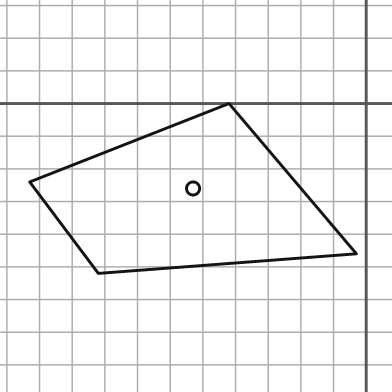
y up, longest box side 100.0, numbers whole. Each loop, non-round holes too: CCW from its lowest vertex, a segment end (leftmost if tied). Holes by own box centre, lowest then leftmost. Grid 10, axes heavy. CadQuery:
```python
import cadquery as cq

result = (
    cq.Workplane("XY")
    .moveTo(-82.0, -52.0)
    .lineTo(-3.0, -46.0)
    .lineTo(-42.0, 0.0)
    .lineTo(-103.0, -24.0)
    .close()
    .moveTo(-53.0, -26.0)
    .circle(2.0)
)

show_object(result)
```